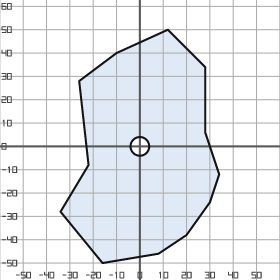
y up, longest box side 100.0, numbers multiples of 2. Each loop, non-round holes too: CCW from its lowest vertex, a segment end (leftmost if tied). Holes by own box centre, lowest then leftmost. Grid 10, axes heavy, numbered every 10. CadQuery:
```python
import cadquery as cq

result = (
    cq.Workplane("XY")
    .moveTo(-16.0, -50.0)
    .lineTo(8.0, -46.0)
    .lineTo(20.0, -38.0)
    .lineTo(30.0, -24.0)
    .lineTo(34.0, -12.0)
    .lineTo(28.0, 6.0)
    .lineTo(28.0, 34.0)
    .lineTo(12.0, 50.0)
    .lineTo(-10.0, 40.0)
    .lineTo(-26.0, 28.0)
    .lineTo(-22.0, -8.0)
    .lineTo(-34.0, -28.0)
    .close()
    .moveTo(0.0, 0.0)
    .circle(4.0)
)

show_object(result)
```